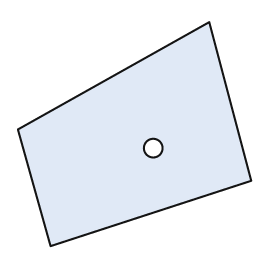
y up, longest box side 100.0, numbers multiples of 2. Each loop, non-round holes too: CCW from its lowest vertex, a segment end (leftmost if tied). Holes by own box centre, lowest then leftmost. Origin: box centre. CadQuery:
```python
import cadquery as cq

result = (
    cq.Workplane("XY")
    .moveTo(-36.0, -48.0)
    .lineTo(50.0, -20.0)
    .lineTo(32.0, 48.0)
    .lineTo(-50.0, 2.0)
    .close()
    .moveTo(8.0, -6.0)
    .circle(4.0)
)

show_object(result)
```